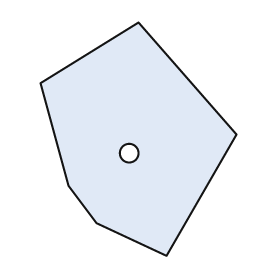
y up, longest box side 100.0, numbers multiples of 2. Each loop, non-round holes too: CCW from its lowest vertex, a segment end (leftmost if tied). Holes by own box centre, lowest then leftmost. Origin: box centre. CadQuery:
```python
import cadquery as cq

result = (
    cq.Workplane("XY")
    .moveTo(12.0, -50.0)
    .lineTo(42.0, 2.0)
    .lineTo(0.0, 50.0)
    .lineTo(-42.0, 24.0)
    .lineTo(-30.0, -20.0)
    .lineTo(-18.0, -36.0)
    .close()
    .moveTo(-4.0, -6.0)
    .circle(4.0)
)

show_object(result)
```